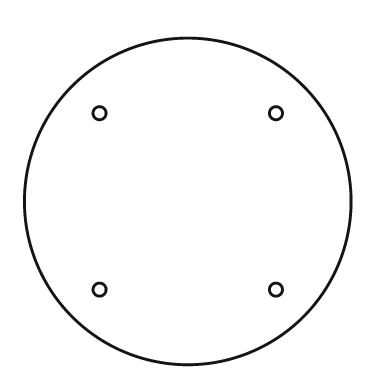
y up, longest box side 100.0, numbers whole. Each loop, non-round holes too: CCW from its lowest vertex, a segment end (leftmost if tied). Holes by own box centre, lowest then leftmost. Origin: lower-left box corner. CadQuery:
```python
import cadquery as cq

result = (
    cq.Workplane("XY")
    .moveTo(50.0, 50.0)
    .circle(50.0)
    .moveTo(23.0, 23.0)
    .circle(2.0)
    .moveTo(77.0, 23.0)
    .circle(2.0)
    .moveTo(23.0, 77.0)
    .circle(2.0)
    .moveTo(77.0, 77.0)
    .circle(2.0)
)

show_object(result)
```